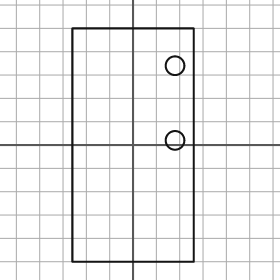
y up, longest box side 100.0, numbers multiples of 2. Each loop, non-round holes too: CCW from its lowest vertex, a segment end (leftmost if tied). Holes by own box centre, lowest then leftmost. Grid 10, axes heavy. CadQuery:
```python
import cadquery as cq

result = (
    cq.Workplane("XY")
    .moveTo(-26.0, -50.0)
    .lineTo(26.0, -50.0)
    .lineTo(26.0, 50.0)
    .lineTo(-26.0, 50.0)
    .close()
    .moveTo(18.0, 2.0)
    .circle(4.0)
    .moveTo(18.0, 34.0)
    .circle(4.0)
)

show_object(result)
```